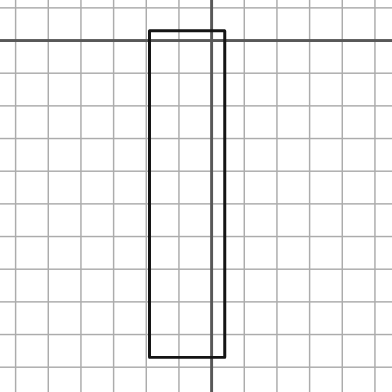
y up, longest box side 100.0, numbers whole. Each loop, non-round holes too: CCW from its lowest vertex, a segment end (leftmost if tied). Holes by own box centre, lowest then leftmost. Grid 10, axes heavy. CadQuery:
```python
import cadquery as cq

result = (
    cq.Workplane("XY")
    .moveTo(-19.0, -97.0)
    .lineTo(4.0, -97.0)
    .lineTo(4.0, 3.0)
    .lineTo(-19.0, 3.0)
    .close()
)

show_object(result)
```